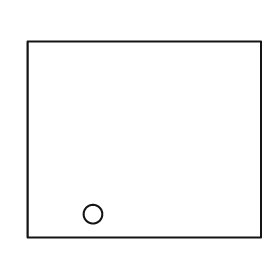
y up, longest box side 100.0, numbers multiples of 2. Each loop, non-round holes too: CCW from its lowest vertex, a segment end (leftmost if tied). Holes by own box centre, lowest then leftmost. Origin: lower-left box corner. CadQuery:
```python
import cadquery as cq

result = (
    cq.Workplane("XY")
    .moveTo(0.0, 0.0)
    .lineTo(100.0, 0.0)
    .lineTo(100.0, 84.0)
    .lineTo(0.0, 84.0)
    .close()
    .moveTo(28.0, 10.0)
    .circle(4.0)
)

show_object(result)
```